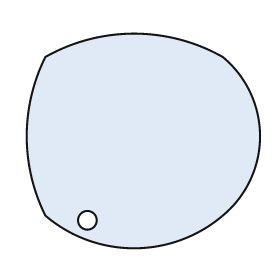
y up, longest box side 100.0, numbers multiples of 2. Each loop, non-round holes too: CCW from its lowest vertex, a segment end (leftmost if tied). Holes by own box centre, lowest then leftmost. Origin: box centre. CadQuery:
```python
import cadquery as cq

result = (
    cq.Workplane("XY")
    .moveTo(-42.0, -32.0)
    .threePointArc((-4.0, -46.0), (34.0, -32.0))
    .threePointArc((50.0, 2.0), (34.0, 36.0))
    .threePointArc((-4.0, 46.0), (-42.0, 36.0))
    .threePointArc((-50.0, 2.0), (-42.0, -32.0))
    .close()
    .moveTo(-24.0, -34.0)
    .circle(4.0)
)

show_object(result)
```